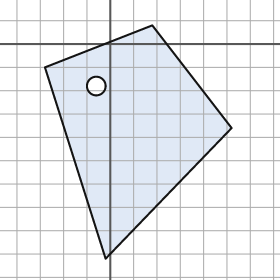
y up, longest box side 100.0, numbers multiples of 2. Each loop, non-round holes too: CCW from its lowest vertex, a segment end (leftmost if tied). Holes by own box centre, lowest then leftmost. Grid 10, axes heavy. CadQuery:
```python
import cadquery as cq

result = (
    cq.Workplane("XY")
    .moveTo(-2.0, -92.0)
    .lineTo(52.0, -36.0)
    .lineTo(18.0, 8.0)
    .lineTo(-28.0, -10.0)
    .close()
    .moveTo(-6.0, -18.0)
    .circle(4.0)
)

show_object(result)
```